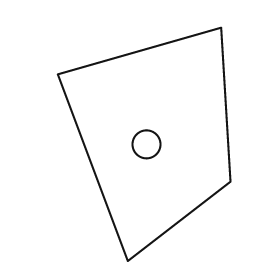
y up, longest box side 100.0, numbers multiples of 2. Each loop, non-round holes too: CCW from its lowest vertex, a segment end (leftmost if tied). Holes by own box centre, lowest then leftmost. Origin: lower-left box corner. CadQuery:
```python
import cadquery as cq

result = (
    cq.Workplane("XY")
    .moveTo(30.0, 0.0)
    .lineTo(74.0, 34.0)
    .lineTo(70.0, 100.0)
    .lineTo(0.0, 80.0)
    .close()
    .moveTo(38.0, 50.0)
    .circle(6.0)
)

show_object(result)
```